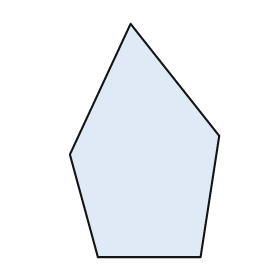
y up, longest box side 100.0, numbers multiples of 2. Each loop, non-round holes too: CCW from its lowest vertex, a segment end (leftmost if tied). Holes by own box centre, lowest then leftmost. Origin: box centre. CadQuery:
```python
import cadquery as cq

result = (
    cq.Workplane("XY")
    .moveTo(-20.0, -50.0)
    .lineTo(24.0, -50.0)
    .lineTo(32.0, 2.0)
    .lineTo(-6.0, 50.0)
    .lineTo(-32.0, -6.0)
    .close()
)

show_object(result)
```